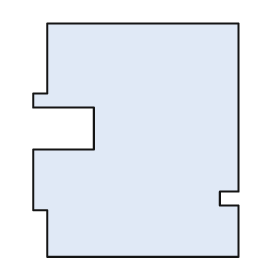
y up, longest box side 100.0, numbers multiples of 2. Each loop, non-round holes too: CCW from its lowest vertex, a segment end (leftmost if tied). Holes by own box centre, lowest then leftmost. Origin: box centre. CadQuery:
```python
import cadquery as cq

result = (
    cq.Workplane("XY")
    .moveTo(-38.0, -50.0)
    .lineTo(44.0, -50.0)
    .lineTo(44.0, -28.0)
    .lineTo(36.0, -28.0)
    .lineTo(36.0, -22.0)
    .lineTo(44.0, -22.0)
    .lineTo(44.0, 50.0)
    .lineTo(-38.0, 50.0)
    .lineTo(-38.0, 20.0)
    .lineTo(-44.0, 20.0)
    .lineTo(-44.0, 14.0)
    .lineTo(-18.0, 14.0)
    .lineTo(-18.0, -4.0)
    .lineTo(-44.0, -4.0)
    .lineTo(-44.0, -30.0)
    .lineTo(-38.0, -30.0)
    .close()
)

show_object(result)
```